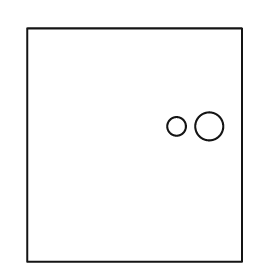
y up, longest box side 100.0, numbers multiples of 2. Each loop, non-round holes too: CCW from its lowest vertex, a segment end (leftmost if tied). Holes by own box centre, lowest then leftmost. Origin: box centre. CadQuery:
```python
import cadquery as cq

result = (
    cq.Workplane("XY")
    .moveTo(-46.0, -50.0)
    .lineTo(46.0, -50.0)
    .lineTo(46.0, 50.0)
    .lineTo(-46.0, 50.0)
    .close()
    .moveTo(18.0, 8.0)
    .circle(4.0)
    .moveTo(32.0, 8.0)
    .circle(6.0)
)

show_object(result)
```